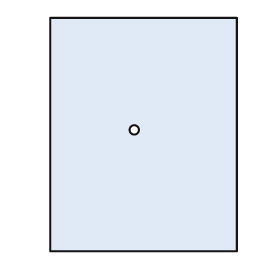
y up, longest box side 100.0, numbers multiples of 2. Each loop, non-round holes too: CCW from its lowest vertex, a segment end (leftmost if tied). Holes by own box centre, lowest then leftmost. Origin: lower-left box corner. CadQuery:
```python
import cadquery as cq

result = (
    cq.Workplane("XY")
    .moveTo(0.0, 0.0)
    .lineTo(80.0, 0.0)
    .lineTo(80.0, 100.0)
    .lineTo(0.0, 100.0)
    .close()
    .moveTo(36.0, 52.0)
    .circle(2.0)
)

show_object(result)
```